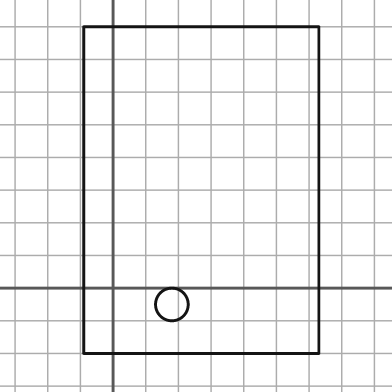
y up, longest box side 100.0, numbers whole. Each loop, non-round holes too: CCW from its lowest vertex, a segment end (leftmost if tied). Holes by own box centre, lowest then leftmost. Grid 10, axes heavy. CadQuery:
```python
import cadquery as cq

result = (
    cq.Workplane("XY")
    .moveTo(-9.0, -20.0)
    .lineTo(63.0, -20.0)
    .lineTo(63.0, 80.0)
    .lineTo(-9.0, 80.0)
    .close()
    .moveTo(18.0, -5.0)
    .circle(5.0)
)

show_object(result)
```